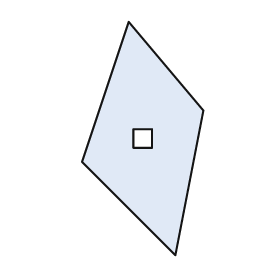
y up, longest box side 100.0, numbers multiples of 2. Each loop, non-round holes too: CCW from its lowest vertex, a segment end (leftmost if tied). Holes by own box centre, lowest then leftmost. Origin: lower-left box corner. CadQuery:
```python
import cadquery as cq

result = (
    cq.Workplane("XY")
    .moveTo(40.0, 0.0)
    .lineTo(52.0, 62.0)
    .lineTo(20.0, 100.0)
    .lineTo(0.0, 40.0)
    .close()
    .moveTo(22.0, 46.0)
    .lineTo(30.0, 46.0)
    .lineTo(30.0, 54.0)
    .lineTo(22.0, 54.0)
    .close()
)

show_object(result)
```